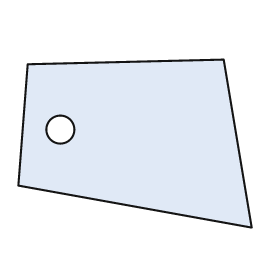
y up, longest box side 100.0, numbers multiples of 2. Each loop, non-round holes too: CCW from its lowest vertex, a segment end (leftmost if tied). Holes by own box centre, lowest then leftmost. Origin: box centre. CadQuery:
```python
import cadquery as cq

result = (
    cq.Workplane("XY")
    .moveTo(50.0, -36.0)
    .lineTo(38.0, 36.0)
    .lineTo(-46.0, 34.0)
    .lineTo(-50.0, -18.0)
    .close()
    .moveTo(-32.0, 6.0)
    .circle(6.0)
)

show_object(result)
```